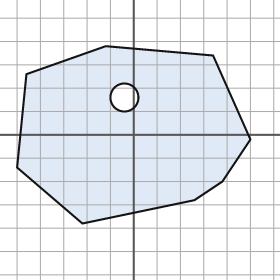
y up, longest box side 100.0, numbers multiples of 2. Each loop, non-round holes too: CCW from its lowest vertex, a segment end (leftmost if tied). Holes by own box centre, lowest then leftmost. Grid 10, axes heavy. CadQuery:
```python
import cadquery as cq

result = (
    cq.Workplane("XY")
    .moveTo(-22.0, -38.0)
    .lineTo(26.0, -28.0)
    .lineTo(38.0, -20.0)
    .lineTo(50.0, -2.0)
    .lineTo(34.0, 34.0)
    .lineTo(-12.0, 38.0)
    .lineTo(-46.0, 26.0)
    .lineTo(-50.0, -14.0)
    .close()
    .moveTo(-4.0, 16.0)
    .circle(6.0)
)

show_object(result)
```